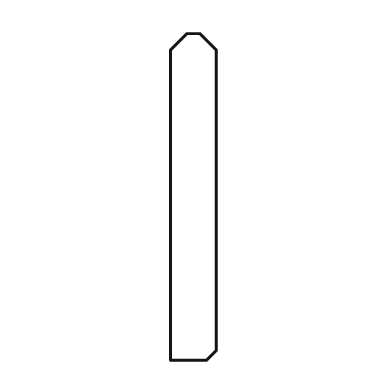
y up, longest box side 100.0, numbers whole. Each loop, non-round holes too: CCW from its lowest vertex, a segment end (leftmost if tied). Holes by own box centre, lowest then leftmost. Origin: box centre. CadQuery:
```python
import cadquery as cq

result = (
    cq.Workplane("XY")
    .moveTo(-7.0, -50.0)
    .lineTo(4.0, -50.0)
    .lineTo(7.0, -47.0)
    .lineTo(7.0, 45.0)
    .lineTo(2.0, 50.0)
    .lineTo(-2.0, 50.0)
    .lineTo(-7.0, 45.0)
    .close()
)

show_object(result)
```